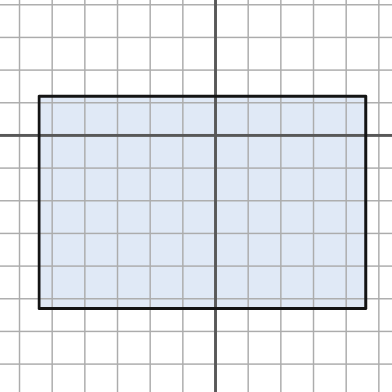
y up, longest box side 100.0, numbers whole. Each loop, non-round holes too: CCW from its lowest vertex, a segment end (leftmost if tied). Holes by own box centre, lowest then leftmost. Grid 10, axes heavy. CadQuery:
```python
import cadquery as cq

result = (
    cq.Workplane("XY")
    .moveTo(-54.0, -53.0)
    .lineTo(46.0, -53.0)
    .lineTo(46.0, 12.0)
    .lineTo(-54.0, 12.0)
    .close()
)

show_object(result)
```